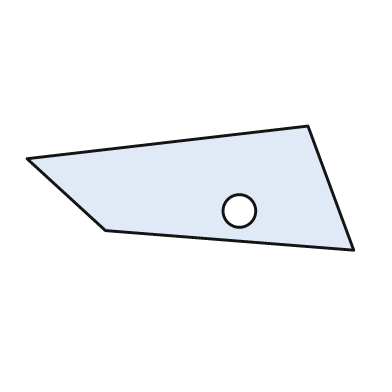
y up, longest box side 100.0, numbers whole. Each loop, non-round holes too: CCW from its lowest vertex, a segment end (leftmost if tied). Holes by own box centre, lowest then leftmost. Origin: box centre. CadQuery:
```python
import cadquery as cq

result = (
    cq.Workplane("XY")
    .moveTo(50.0, -19.0)
    .lineTo(36.0, 19.0)
    .lineTo(-50.0, 9.0)
    .lineTo(-26.0, -13.0)
    .close()
    .moveTo(15.0, -7.0)
    .circle(5.0)
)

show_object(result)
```